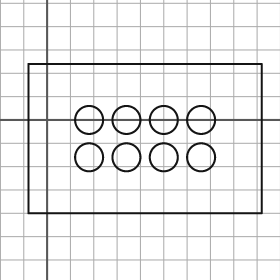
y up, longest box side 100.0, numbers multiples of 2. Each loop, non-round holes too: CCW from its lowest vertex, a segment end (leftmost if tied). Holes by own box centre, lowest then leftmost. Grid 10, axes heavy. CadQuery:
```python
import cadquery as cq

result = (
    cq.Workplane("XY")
    .moveTo(-8.0, -40.0)
    .lineTo(92.0, -40.0)
    .lineTo(92.0, 24.0)
    .lineTo(-8.0, 24.0)
    .close()
    .moveTo(18.0, -16.0)
    .circle(6.0)
    .moveTo(34.0, -16.0)
    .circle(6.0)
    .moveTo(50.0, -16.0)
    .circle(6.0)
    .moveTo(66.0, -16.0)
    .circle(6.0)
    .moveTo(18.0, 0.0)
    .circle(6.0)
    .moveTo(34.0, 0.0)
    .circle(6.0)
    .moveTo(50.0, 0.0)
    .circle(6.0)
    .moveTo(66.0, 0.0)
    .circle(6.0)
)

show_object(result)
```